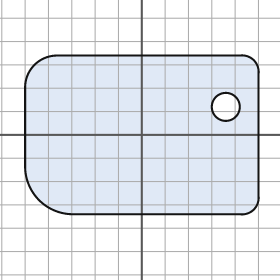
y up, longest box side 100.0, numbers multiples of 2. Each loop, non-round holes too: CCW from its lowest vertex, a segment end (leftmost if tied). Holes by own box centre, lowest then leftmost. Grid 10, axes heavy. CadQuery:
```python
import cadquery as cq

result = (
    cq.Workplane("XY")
    .moveTo(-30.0, -34.0)
    .lineTo(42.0, -34.0)
    .threePointArc((48.0, -32.0), (50.0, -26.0))
    .lineTo(50.0, 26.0)
    .threePointArc((48.0, 32.0), (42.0, 34.0))
    .lineTo(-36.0, 34.0)
    .threePointArc((-46.0, 30.0), (-50.0, 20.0))
    .lineTo(-50.0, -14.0)
    .threePointArc((-44.0, -28.0), (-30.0, -34.0))
    .close()
    .moveTo(36.0, 12.0)
    .circle(6.0)
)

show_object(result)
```